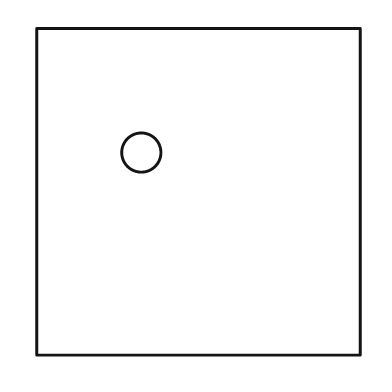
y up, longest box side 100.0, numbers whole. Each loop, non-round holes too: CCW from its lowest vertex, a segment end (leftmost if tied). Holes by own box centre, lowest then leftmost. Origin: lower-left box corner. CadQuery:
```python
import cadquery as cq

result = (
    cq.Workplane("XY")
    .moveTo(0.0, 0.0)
    .lineTo(99.0, 0.0)
    .lineTo(99.0, 100.0)
    .lineTo(0.0, 100.0)
    .close()
    .moveTo(32.0, 62.0)
    .circle(6.0)
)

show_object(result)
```